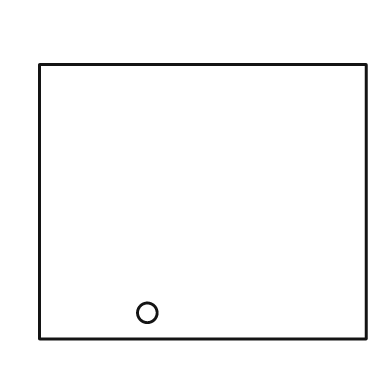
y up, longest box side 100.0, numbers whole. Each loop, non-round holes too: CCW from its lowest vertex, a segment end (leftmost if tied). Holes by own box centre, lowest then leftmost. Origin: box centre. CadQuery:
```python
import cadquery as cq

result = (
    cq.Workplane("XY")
    .moveTo(-50.0, -42.0)
    .lineTo(50.0, -42.0)
    .lineTo(50.0, 42.0)
    .lineTo(-50.0, 42.0)
    .close()
    .moveTo(-17.0, -34.0)
    .circle(3.0)
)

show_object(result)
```